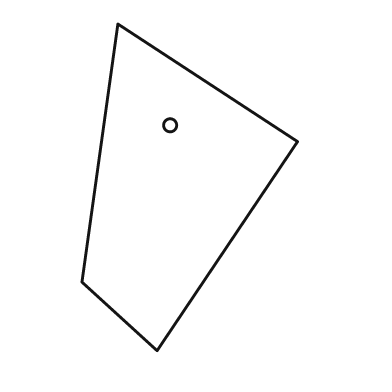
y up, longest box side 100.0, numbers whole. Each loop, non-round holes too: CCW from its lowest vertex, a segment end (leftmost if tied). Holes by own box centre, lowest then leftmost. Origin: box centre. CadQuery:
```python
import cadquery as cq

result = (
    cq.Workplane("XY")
    .moveTo(-10.0, -50.0)
    .lineTo(33.0, 14.0)
    .lineTo(-22.0, 50.0)
    .lineTo(-33.0, -29.0)
    .close()
    .moveTo(-6.0, 19.0)
    .circle(2.0)
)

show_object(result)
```